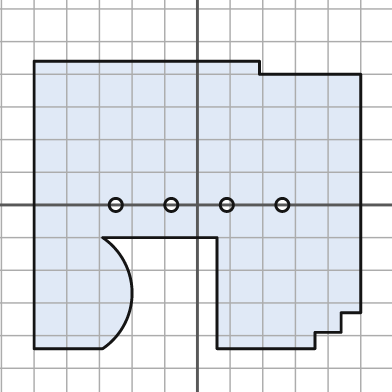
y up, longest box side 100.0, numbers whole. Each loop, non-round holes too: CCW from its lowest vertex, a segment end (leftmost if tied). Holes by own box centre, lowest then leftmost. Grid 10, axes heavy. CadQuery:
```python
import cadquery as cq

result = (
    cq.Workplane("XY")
    .moveTo(-50.0, -44.0)
    .lineTo(-29.0, -44.0)
    .threePointArc((-20.0, -27.0), (-29.0, -10.0))
    .lineTo(6.0, -10.0)
    .lineTo(6.0, -44.0)
    .lineTo(36.0, -44.0)
    .lineTo(36.0, -39.0)
    .lineTo(44.0, -39.0)
    .lineTo(44.0, -33.0)
    .lineTo(50.0, -33.0)
    .lineTo(50.0, 40.0)
    .lineTo(19.0, 40.0)
    .lineTo(19.0, 44.0)
    .lineTo(-50.0, 44.0)
    .close()
    .moveTo(-25.0, 0.0)
    .circle(2.0)
    .moveTo(-8.0, 0.0)
    .circle(2.0)
    .moveTo(9.0, 0.0)
    .circle(2.0)
    .moveTo(26.0, 0.0)
    .circle(2.0)
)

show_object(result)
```